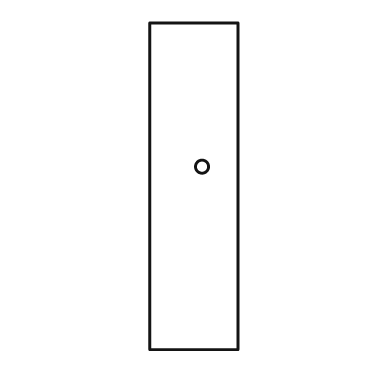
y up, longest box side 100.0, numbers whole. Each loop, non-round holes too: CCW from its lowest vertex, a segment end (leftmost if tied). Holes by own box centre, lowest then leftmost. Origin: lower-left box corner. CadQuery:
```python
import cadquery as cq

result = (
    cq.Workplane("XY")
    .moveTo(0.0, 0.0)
    .lineTo(27.0, 0.0)
    .lineTo(27.0, 100.0)
    .lineTo(0.0, 100.0)
    .close()
    .moveTo(16.0, 56.0)
    .circle(2.0)
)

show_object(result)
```